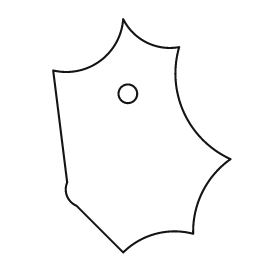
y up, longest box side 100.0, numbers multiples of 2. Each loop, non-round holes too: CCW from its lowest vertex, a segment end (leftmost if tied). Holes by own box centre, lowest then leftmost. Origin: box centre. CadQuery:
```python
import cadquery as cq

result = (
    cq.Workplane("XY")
    .moveTo(-8.0, -50.0)
    .threePointArc((6.0, -42.0), (22.0, -42.0))
    .threePointArc((26.0, -24.0), (38.0, -10.0))
    .threePointArc((18.0, 10.0), (16.0, 38.0))
    .threePointArc((2.0, 40.0), (-8.0, 50.0))
    .threePointArc((-18.0, 32.0), (-38.0, 28.0))
    .lineTo(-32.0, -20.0)
    .threePointArc((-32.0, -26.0), (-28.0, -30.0))
    .close()
    .moveTo(-6.0, 18.0)
    .circle(4.0)
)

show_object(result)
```